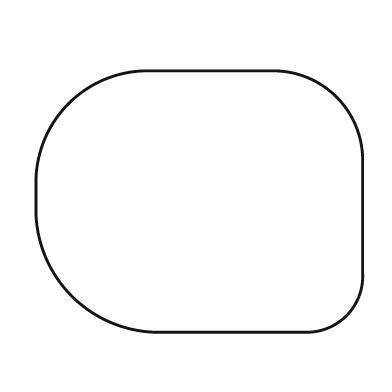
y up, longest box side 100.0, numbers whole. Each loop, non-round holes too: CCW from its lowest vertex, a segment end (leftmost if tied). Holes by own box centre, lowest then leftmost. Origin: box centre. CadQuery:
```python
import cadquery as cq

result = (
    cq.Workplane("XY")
    .moveTo(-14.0, -40.0)
    .lineTo(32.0, -40.0)
    .threePointArc((45.0, -35.0), (50.0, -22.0))
    .lineTo(50.0, 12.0)
    .threePointArc((42.0, 32.0), (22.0, 40.0))
    .lineTo(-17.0, 40.0)
    .threePointArc((-40.0, 30.0), (-50.0, 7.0))
    .lineTo(-50.0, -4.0)
    .threePointArc((-39.0, -29.0), (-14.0, -40.0))
    .close()
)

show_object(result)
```